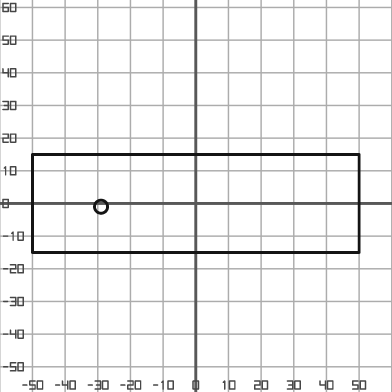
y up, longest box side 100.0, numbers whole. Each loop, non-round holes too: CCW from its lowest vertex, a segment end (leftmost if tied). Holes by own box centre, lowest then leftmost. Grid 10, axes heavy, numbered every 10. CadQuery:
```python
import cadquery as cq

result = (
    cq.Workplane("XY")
    .moveTo(-50.0, -15.0)
    .lineTo(50.0, -15.0)
    .lineTo(50.0, 15.0)
    .lineTo(-50.0, 15.0)
    .close()
    .moveTo(-29.0, -1.0)
    .circle(2.0)
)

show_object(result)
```